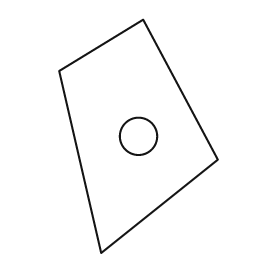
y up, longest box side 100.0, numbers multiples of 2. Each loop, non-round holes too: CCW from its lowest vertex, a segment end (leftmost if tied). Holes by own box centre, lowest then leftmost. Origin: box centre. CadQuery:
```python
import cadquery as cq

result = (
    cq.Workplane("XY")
    .moveTo(-16.0, -50.0)
    .lineTo(34.0, -10.0)
    .lineTo(2.0, 50.0)
    .lineTo(-34.0, 28.0)
    .close()
    .moveTo(0.0, 0.0)
    .circle(8.0)
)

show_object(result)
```